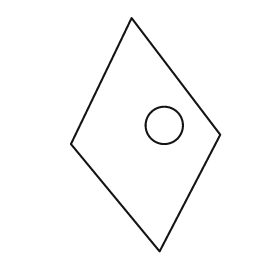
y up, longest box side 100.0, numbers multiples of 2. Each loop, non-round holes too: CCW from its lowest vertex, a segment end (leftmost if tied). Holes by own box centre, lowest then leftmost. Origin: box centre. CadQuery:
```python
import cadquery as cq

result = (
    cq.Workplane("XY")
    .moveTo(6.0, -50.0)
    .lineTo(32.0, 0.0)
    .lineTo(-6.0, 50.0)
    .lineTo(-32.0, -4.0)
    .close()
    .moveTo(8.0, 4.0)
    .circle(8.0)
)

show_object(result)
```